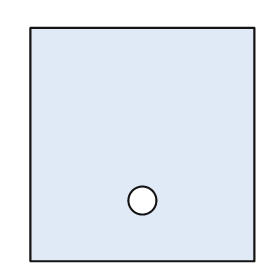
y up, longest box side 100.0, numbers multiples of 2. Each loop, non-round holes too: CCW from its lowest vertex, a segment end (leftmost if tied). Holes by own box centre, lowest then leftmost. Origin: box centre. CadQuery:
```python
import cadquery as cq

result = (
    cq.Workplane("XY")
    .moveTo(-48.0, -50.0)
    .lineTo(48.0, -50.0)
    .lineTo(48.0, 50.0)
    .lineTo(-48.0, 50.0)
    .close()
    .moveTo(0.0, -24.0)
    .circle(6.0)
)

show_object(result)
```